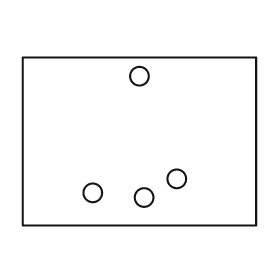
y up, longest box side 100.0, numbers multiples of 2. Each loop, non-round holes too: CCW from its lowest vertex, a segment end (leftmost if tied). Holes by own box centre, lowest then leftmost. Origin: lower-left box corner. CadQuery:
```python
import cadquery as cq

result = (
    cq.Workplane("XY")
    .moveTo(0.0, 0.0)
    .lineTo(100.0, 0.0)
    .lineTo(100.0, 72.0)
    .lineTo(0.0, 72.0)
    .close()
    .moveTo(52.0, 12.0)
    .circle(4.0)
    .moveTo(30.0, 14.0)
    .circle(4.0)
    .moveTo(66.0, 20.0)
    .circle(4.0)
    .moveTo(50.0, 64.0)
    .circle(4.0)
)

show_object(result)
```